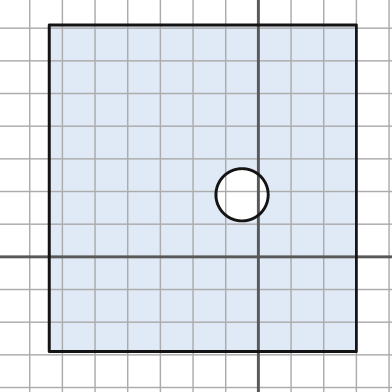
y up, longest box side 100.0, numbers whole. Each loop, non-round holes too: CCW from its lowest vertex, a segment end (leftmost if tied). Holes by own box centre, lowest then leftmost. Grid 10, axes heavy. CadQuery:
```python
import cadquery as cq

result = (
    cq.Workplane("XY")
    .moveTo(-64.0, -29.0)
    .lineTo(30.0, -29.0)
    .lineTo(30.0, 71.0)
    .lineTo(-64.0, 71.0)
    .close()
    .moveTo(-5.0, 19.0)
    .circle(8.0)
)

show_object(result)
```